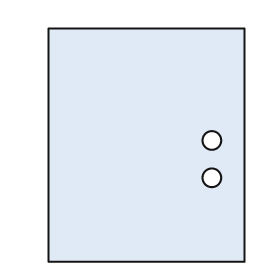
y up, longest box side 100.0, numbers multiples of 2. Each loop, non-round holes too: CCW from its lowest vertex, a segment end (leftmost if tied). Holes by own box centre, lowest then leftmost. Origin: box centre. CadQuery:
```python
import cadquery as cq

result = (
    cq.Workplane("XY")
    .moveTo(-42.0, -50.0)
    .lineTo(42.0, -50.0)
    .lineTo(42.0, 50.0)
    .lineTo(-42.0, 50.0)
    .close()
    .moveTo(28.0, -14.0)
    .circle(4.0)
    .moveTo(28.0, 2.0)
    .circle(4.0)
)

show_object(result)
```